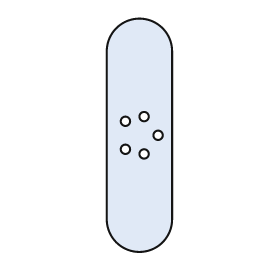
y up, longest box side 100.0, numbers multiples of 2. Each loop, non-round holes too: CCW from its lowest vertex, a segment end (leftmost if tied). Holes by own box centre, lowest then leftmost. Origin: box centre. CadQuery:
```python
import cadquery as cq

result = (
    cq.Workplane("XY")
    .moveTo(-14.0, -36.0)
    .threePointArc((0.0, -50.0), (14.0, -36.0))
    .lineTo(14.0, 36.0)
    .threePointArc((0.0, 50.0), (-14.0, 36.0))
    .close()
    .moveTo(2.0, -8.0)
    .circle(2.0)
    .moveTo(-6.0, -6.0)
    .circle(2.0)
    .moveTo(8.0, 0.0)
    .circle(2.0)
    .moveTo(-6.0, 6.0)
    .circle(2.0)
    .moveTo(2.0, 8.0)
    .circle(2.0)
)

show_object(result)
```